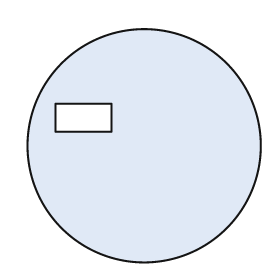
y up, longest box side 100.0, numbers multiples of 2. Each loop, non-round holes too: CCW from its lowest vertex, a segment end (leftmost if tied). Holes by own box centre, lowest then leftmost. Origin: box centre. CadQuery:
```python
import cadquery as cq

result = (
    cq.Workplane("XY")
    .moveTo(0.0, 0.0)
    .circle(50.0)
    .moveTo(-38.0, 6.0)
    .lineTo(-14.0, 6.0)
    .lineTo(-14.0, 18.0)
    .lineTo(-38.0, 18.0)
    .close()
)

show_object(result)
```